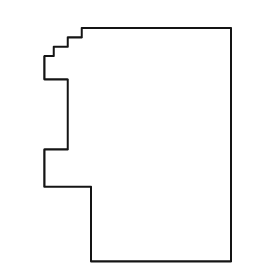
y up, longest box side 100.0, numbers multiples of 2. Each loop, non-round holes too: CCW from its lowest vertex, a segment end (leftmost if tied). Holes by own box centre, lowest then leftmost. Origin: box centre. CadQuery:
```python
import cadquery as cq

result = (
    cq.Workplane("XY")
    .moveTo(-20.0, -50.0)
    .lineTo(40.0, -50.0)
    .lineTo(40.0, 50.0)
    .lineTo(-24.0, 50.0)
    .lineTo(-24.0, 46.0)
    .lineTo(-30.0, 46.0)
    .lineTo(-30.0, 42.0)
    .lineTo(-36.0, 42.0)
    .lineTo(-36.0, 38.0)
    .lineTo(-40.0, 38.0)
    .lineTo(-40.0, 28.0)
    .lineTo(-30.0, 28.0)
    .lineTo(-30.0, -2.0)
    .lineTo(-40.0, -2.0)
    .lineTo(-40.0, -18.0)
    .lineTo(-20.0, -18.0)
    .close()
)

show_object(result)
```